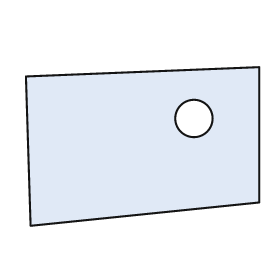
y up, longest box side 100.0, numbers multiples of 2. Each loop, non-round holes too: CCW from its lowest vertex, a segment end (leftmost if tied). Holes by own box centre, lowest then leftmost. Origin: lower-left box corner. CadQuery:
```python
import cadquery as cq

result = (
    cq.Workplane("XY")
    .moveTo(2.0, 0.0)
    .lineTo(100.0, 10.0)
    .lineTo(100.0, 68.0)
    .lineTo(0.0, 64.0)
    .close()
    .moveTo(72.0, 46.0)
    .circle(8.0)
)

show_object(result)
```